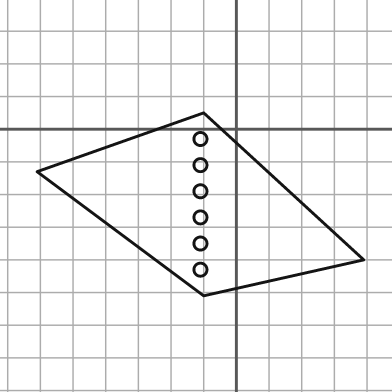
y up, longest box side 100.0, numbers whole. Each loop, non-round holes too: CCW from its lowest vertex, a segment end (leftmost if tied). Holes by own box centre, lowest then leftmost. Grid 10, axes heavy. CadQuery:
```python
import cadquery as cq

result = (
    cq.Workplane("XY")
    .moveTo(-10.0, -51.0)
    .lineTo(39.0, -40.0)
    .lineTo(-10.0, 5.0)
    .lineTo(-61.0, -13.0)
    .close()
    .moveTo(-11.0, -43.0)
    .circle(2.0)
    .moveTo(-11.0, -35.0)
    .circle(2.0)
    .moveTo(-11.0, -27.0)
    .circle(2.0)
    .moveTo(-11.0, -19.0)
    .circle(2.0)
    .moveTo(-11.0, -11.0)
    .circle(2.0)
    .moveTo(-11.0, -3.0)
    .circle(2.0)
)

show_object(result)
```